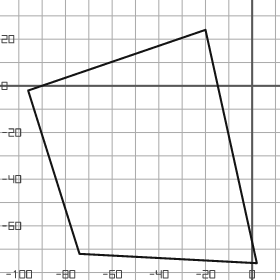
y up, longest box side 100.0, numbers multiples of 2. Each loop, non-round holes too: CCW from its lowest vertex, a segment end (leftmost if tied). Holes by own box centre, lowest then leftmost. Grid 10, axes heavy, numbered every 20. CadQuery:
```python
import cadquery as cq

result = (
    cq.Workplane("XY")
    .moveTo(2.0, -76.0)
    .lineTo(-20.0, 24.0)
    .lineTo(-96.0, -2.0)
    .lineTo(-74.0, -72.0)
    .close()
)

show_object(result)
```